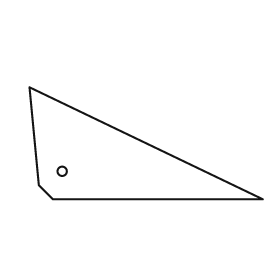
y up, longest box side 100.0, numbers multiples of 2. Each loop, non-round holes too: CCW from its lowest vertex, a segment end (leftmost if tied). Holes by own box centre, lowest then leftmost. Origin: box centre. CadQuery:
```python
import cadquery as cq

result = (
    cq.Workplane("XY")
    .moveTo(-40.0, -24.0)
    .lineTo(50.0, -24.0)
    .lineTo(-50.0, 24.0)
    .lineTo(-46.0, -18.0)
    .close()
    .moveTo(-36.0, -12.0)
    .circle(2.0)
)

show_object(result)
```